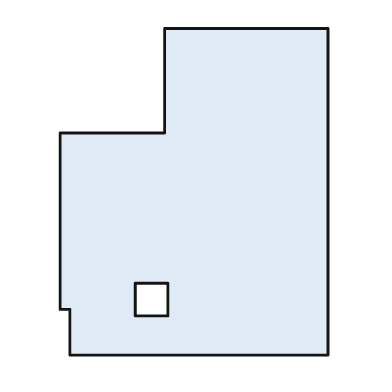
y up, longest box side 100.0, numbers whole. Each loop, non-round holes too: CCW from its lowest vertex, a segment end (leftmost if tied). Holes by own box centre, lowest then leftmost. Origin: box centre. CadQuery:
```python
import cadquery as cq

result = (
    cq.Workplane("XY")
    .moveTo(-38.0, -50.0)
    .lineTo(41.0, -50.0)
    .lineTo(41.0, 50.0)
    .lineTo(-9.0, 50.0)
    .lineTo(-9.0, 18.0)
    .lineTo(-41.0, 18.0)
    .lineTo(-41.0, -36.0)
    .lineTo(-38.0, -36.0)
    .close()
    .moveTo(-18.0, -38.0)
    .lineTo(-8.0, -38.0)
    .lineTo(-8.0, -28.0)
    .lineTo(-18.0, -28.0)
    .close()
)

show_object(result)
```